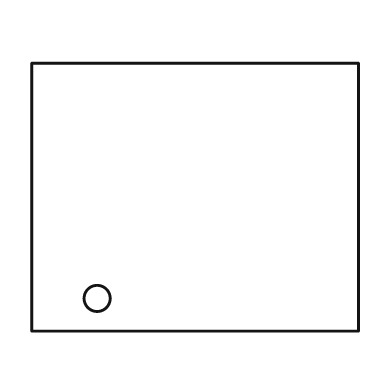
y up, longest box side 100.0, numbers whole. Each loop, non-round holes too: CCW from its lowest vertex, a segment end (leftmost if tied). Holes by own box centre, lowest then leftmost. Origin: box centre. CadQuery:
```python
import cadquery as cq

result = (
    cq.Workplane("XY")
    .moveTo(-50.0, -41.0)
    .lineTo(50.0, -41.0)
    .lineTo(50.0, 41.0)
    .lineTo(-50.0, 41.0)
    .close()
    .moveTo(-30.0, -31.0)
    .circle(4.0)
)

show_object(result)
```